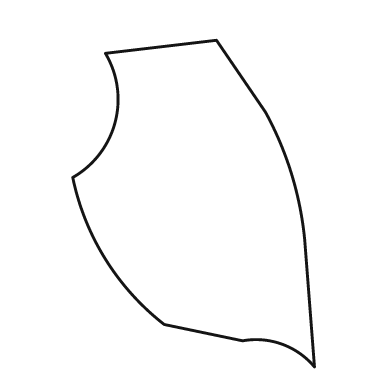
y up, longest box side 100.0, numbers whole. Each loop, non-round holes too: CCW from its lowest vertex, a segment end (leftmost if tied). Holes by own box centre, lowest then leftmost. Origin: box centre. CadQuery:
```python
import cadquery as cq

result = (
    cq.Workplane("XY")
    .moveTo(37.0, -50.0)
    .lineTo(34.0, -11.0)
    .threePointArc((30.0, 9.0), (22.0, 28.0))
    .lineTo(7.0, 50.0)
    .lineTo(-27.0, 46.0)
    .threePointArc((-24.0, 25.0), (-37.0, 8.0))
    .threePointArc((-27.0, -17.0), (-9.0, -37.0))
    .lineTo(15.0, -42.0)
    .threePointArc((27.0, -43.0), (37.0, -50.0))
    .close()
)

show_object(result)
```